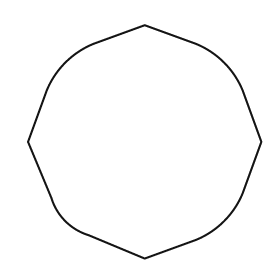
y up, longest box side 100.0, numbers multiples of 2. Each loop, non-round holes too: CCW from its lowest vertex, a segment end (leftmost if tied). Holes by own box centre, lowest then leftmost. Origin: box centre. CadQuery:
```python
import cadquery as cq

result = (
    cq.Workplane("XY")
    .moveTo(0.0, -50.0)
    .lineTo(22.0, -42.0)
    .threePointArc((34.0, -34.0), (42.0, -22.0))
    .lineTo(50.0, 0.0)
    .lineTo(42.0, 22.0)
    .threePointArc((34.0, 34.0), (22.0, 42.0))
    .lineTo(0.0, 50.0)
    .lineTo(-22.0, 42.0)
    .threePointArc((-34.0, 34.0), (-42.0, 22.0))
    .lineTo(-50.0, 0.0)
    .lineTo(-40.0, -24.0)
    .threePointArc((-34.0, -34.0), (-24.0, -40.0))
    .close()
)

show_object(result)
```